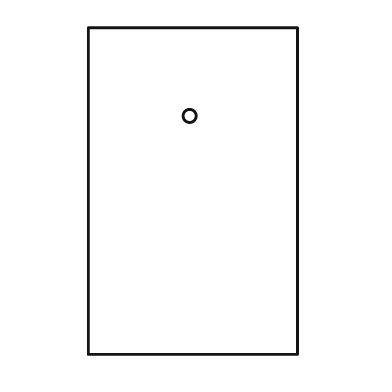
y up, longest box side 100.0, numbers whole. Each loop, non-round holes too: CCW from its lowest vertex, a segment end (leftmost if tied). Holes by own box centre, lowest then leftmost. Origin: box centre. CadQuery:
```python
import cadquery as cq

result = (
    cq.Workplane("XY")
    .moveTo(-32.0, -50.0)
    .lineTo(32.0, -50.0)
    .lineTo(32.0, 50.0)
    .lineTo(-32.0, 50.0)
    .close()
    .moveTo(-1.0, 23.0)
    .circle(2.0)
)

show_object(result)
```